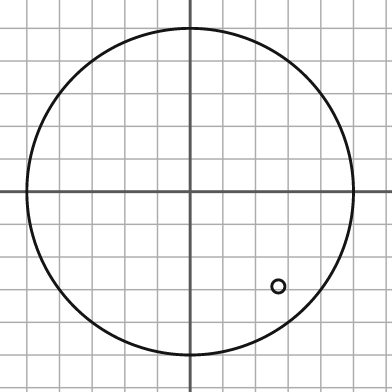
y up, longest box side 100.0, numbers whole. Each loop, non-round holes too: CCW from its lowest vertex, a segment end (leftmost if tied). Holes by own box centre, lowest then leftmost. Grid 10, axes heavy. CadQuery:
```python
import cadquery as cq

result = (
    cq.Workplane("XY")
    .moveTo(0.0, 0.0)
    .circle(50.0)
    .moveTo(27.0, -29.0)
    .circle(2.0)
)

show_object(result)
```